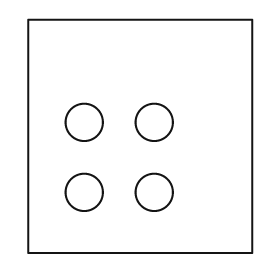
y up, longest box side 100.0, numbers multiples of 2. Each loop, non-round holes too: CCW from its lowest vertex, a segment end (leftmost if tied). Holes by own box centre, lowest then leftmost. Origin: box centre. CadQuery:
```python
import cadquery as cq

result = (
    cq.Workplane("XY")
    .moveTo(-48.0, -50.0)
    .lineTo(48.0, -50.0)
    .lineTo(48.0, 50.0)
    .lineTo(-48.0, 50.0)
    .close()
    .moveTo(-24.0, -24.0)
    .circle(8.0)
    .moveTo(6.0, -24.0)
    .circle(8.0)
    .moveTo(-24.0, 6.0)
    .circle(8.0)
    .moveTo(6.0, 6.0)
    .circle(8.0)
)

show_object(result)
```